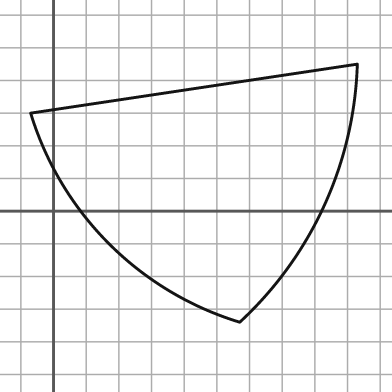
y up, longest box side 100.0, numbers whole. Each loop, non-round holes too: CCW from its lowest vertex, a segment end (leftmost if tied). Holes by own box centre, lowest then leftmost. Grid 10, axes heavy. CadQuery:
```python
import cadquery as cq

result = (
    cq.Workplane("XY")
    .moveTo(57.0, -34.0)
    .threePointArc((83.0, 2.0), (93.0, 45.0))
    .lineTo(-7.0, 30.0)
    .threePointArc((17.0, -10.0), (57.0, -34.0))
    .close()
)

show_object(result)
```